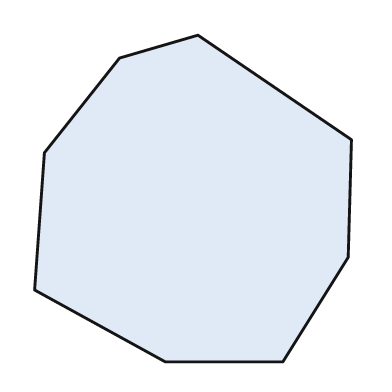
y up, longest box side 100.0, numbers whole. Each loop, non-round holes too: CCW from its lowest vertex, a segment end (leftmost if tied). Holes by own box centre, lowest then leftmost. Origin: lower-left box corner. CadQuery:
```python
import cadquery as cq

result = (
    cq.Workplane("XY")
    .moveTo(40.0, 0.0)
    .lineTo(76.0, 0.0)
    .lineTo(96.0, 32.0)
    .lineTo(97.0, 68.0)
    .lineTo(50.0, 100.0)
    .lineTo(26.0, 93.0)
    .lineTo(3.0, 64.0)
    .lineTo(0.0, 22.0)
    .close()
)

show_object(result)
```